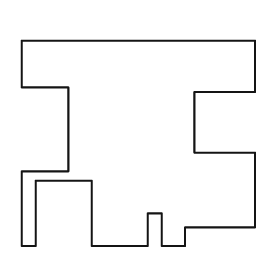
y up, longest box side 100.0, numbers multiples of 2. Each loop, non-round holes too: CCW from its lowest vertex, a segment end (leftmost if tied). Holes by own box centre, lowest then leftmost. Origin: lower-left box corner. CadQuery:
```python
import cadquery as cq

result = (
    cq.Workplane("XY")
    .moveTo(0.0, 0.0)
    .lineTo(6.0, 0.0)
    .lineTo(6.0, 28.0)
    .lineTo(30.0, 28.0)
    .lineTo(30.0, 0.0)
    .lineTo(54.0, 0.0)
    .lineTo(54.0, 14.0)
    .lineTo(60.0, 14.0)
    .lineTo(60.0, 0.0)
    .lineTo(70.0, 0.0)
    .lineTo(70.0, 8.0)
    .lineTo(100.0, 8.0)
    .lineTo(100.0, 40.0)
    .lineTo(74.0, 40.0)
    .lineTo(74.0, 66.0)
    .lineTo(100.0, 66.0)
    .lineTo(100.0, 88.0)
    .lineTo(0.0, 88.0)
    .lineTo(0.0, 68.0)
    .lineTo(20.0, 68.0)
    .lineTo(20.0, 32.0)
    .lineTo(0.0, 32.0)
    .close()
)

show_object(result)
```